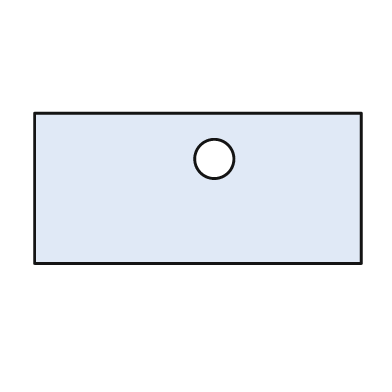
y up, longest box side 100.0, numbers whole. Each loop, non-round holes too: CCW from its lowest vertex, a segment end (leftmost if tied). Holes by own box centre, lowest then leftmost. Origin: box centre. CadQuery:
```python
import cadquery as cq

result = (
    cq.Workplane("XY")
    .moveTo(-50.0, -23.0)
    .lineTo(50.0, -23.0)
    .lineTo(50.0, 23.0)
    .lineTo(-50.0, 23.0)
    .close()
    .moveTo(5.0, 9.0)
    .circle(6.0)
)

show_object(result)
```